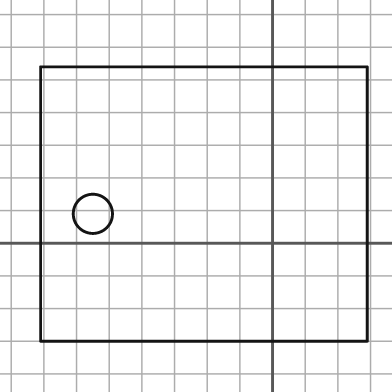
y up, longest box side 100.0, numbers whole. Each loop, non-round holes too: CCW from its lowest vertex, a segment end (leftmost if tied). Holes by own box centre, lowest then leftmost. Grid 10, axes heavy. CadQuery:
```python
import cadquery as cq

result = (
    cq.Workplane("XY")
    .moveTo(-71.0, -30.0)
    .lineTo(29.0, -30.0)
    .lineTo(29.0, 54.0)
    .lineTo(-71.0, 54.0)
    .close()
    .moveTo(-55.0, 9.0)
    .circle(6.0)
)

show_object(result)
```